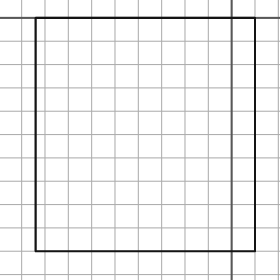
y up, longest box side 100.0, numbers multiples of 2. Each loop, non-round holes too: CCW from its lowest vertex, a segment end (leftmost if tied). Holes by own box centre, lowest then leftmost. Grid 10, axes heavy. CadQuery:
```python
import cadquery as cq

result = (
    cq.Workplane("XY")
    .moveTo(-84.0, -100.0)
    .lineTo(10.0, -100.0)
    .lineTo(10.0, 0.0)
    .lineTo(-84.0, 0.0)
    .close()
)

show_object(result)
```